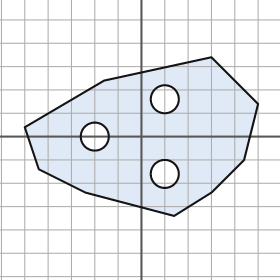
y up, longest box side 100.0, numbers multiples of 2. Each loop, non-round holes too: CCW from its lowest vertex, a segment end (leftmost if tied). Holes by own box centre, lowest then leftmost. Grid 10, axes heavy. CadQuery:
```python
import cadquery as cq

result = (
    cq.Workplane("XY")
    .moveTo(14.0, -34.0)
    .lineTo(30.0, -24.0)
    .lineTo(44.0, -10.0)
    .lineTo(50.0, 14.0)
    .lineTo(30.0, 34.0)
    .lineTo(-16.0, 24.0)
    .lineTo(-50.0, 4.0)
    .lineTo(-44.0, -14.0)
    .lineTo(-24.0, -24.0)
    .close()
    .moveTo(10.0, -16.0)
    .circle(6.0)
    .moveTo(-20.0, 0.0)
    .circle(6.0)
    .moveTo(10.0, 16.0)
    .circle(6.0)
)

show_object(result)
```